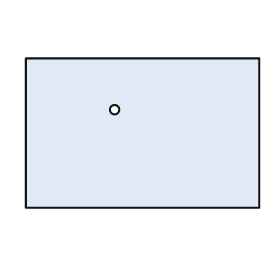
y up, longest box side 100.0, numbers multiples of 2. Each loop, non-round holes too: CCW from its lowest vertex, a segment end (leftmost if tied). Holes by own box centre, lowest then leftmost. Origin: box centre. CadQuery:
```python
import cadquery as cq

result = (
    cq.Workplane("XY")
    .moveTo(-50.0, -32.0)
    .lineTo(50.0, -32.0)
    .lineTo(50.0, 32.0)
    .lineTo(-50.0, 32.0)
    .close()
    .moveTo(-12.0, 10.0)
    .circle(2.0)
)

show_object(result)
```